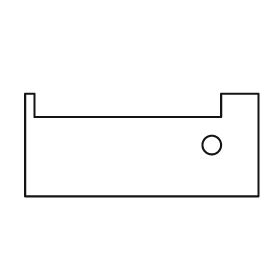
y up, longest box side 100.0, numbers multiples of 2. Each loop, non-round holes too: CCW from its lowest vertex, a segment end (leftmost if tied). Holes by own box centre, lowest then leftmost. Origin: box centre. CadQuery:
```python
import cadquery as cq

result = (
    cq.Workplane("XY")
    .moveTo(-50.0, -22.0)
    .lineTo(50.0, -22.0)
    .lineTo(50.0, 22.0)
    .lineTo(34.0, 22.0)
    .lineTo(34.0, 12.0)
    .lineTo(-46.0, 12.0)
    .lineTo(-46.0, 22.0)
    .lineTo(-50.0, 22.0)
    .close()
    .moveTo(30.0, 0.0)
    .circle(4.0)
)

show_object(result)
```